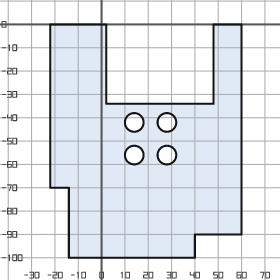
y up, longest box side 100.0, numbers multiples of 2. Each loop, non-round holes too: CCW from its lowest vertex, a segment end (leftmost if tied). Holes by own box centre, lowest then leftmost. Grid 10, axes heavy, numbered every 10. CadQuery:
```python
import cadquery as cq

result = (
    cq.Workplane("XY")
    .moveTo(-14.0, -100.0)
    .lineTo(40.0, -100.0)
    .lineTo(40.0, -90.0)
    .lineTo(60.0, -90.0)
    .lineTo(60.0, 0.0)
    .lineTo(48.0, 0.0)
    .lineTo(48.0, -34.0)
    .lineTo(2.0, -34.0)
    .lineTo(2.0, 0.0)
    .lineTo(-22.0, 0.0)
    .lineTo(-22.0, -70.0)
    .lineTo(-14.0, -70.0)
    .close()
    .moveTo(14.0, -56.0)
    .circle(4.0)
    .moveTo(28.0, -56.0)
    .circle(4.0)
    .moveTo(14.0, -42.0)
    .circle(4.0)
    .moveTo(28.0, -42.0)
    .circle(4.0)
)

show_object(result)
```